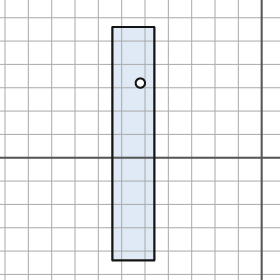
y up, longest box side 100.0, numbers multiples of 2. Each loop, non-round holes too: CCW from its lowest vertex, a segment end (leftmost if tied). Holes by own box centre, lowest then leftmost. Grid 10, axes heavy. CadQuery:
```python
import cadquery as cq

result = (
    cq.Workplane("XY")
    .moveTo(-64.0, -44.0)
    .lineTo(-46.0, -44.0)
    .lineTo(-46.0, 56.0)
    .lineTo(-64.0, 56.0)
    .close()
    .moveTo(-52.0, 32.0)
    .circle(2.0)
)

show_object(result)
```